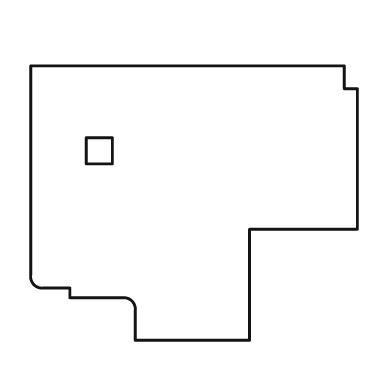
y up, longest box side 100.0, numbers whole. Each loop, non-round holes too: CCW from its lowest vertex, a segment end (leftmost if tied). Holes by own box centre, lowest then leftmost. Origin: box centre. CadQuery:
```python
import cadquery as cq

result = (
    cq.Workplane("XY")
    .moveTo(-18.0, -42.0)
    .lineTo(17.0, -42.0)
    .lineTo(17.0, -8.0)
    .lineTo(50.0, -8.0)
    .lineTo(50.0, 35.0)
    .lineTo(46.0, 35.0)
    .lineTo(46.0, 42.0)
    .lineTo(-50.0, 42.0)
    .lineTo(-50.0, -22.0)
    .threePointArc((-49.0, -25.0), (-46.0, -26.0))
    .lineTo(-38.0, -26.0)
    .lineTo(-38.0, -29.0)
    .lineTo(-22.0, -29.0)
    .threePointArc((-19.0, -30.0), (-18.0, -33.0))
    .close()
    .moveTo(-33.0, 12.0)
    .lineTo(-25.0, 12.0)
    .lineTo(-25.0, 20.0)
    .lineTo(-33.0, 20.0)
    .close()
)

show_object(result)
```